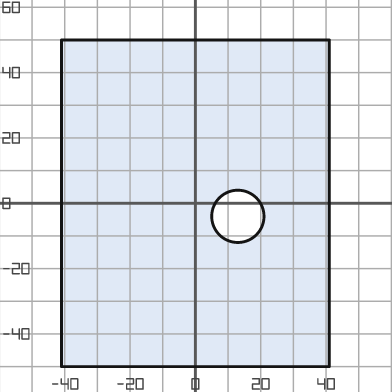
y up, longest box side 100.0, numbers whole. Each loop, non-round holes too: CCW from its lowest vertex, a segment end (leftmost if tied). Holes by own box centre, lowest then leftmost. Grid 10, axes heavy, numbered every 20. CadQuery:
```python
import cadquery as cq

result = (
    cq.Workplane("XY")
    .moveTo(-41.0, -50.0)
    .lineTo(41.0, -50.0)
    .lineTo(41.0, 50.0)
    .lineTo(-41.0, 50.0)
    .close()
    .moveTo(13.0, -4.0)
    .circle(8.0)
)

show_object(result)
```